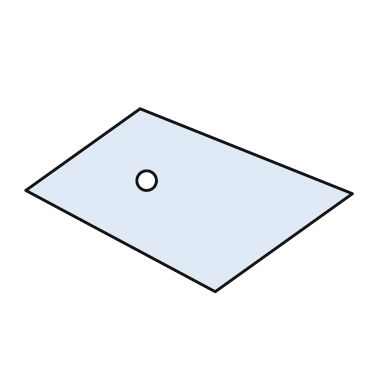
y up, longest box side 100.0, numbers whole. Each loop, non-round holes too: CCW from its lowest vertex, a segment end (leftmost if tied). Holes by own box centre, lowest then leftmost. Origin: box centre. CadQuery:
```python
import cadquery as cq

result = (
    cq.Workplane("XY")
    .moveTo(8.0, -28.0)
    .lineTo(50.0, 2.0)
    .lineTo(-15.0, 28.0)
    .lineTo(-50.0, 3.0)
    .close()
    .moveTo(-13.0, 6.0)
    .circle(3.0)
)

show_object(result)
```